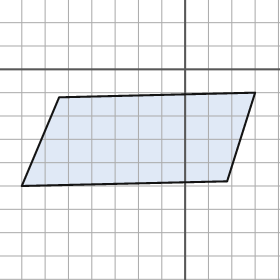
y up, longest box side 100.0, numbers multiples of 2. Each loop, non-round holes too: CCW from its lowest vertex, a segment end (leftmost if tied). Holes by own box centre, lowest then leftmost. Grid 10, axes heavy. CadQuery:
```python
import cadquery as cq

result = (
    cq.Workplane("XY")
    .moveTo(-70.0, -50.0)
    .lineTo(18.0, -48.0)
    .lineTo(30.0, -10.0)
    .lineTo(-54.0, -12.0)
    .close()
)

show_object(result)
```